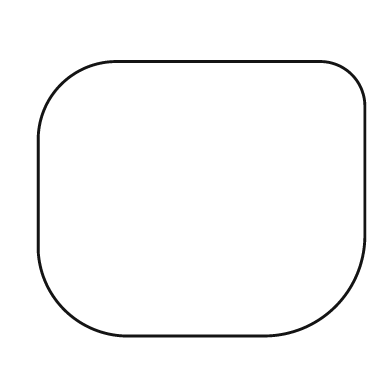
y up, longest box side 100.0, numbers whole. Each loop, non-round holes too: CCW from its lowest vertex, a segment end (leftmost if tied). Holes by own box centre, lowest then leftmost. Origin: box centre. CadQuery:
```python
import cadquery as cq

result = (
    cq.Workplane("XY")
    .moveTo(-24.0, -42.0)
    .lineTo(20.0, -42.0)
    .threePointArc((41.0, -33.0), (50.0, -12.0))
    .lineTo(50.0, 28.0)
    .threePointArc((46.0, 38.0), (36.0, 42.0))
    .lineTo(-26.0, 42.0)
    .threePointArc((-43.0, 35.0), (-50.0, 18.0))
    .lineTo(-50.0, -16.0)
    .threePointArc((-42.0, -34.0), (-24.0, -42.0))
    .close()
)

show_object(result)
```